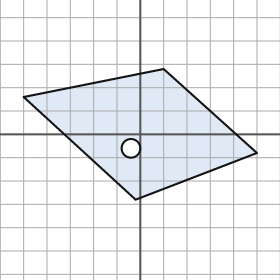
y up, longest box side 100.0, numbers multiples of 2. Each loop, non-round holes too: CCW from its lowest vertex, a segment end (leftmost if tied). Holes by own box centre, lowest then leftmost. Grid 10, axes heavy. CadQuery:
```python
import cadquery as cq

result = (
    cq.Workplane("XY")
    .moveTo(-2.0, -28.0)
    .lineTo(50.0, -8.0)
    .lineTo(10.0, 28.0)
    .lineTo(-50.0, 16.0)
    .close()
    .moveTo(-4.0, -6.0)
    .circle(4.0)
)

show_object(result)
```